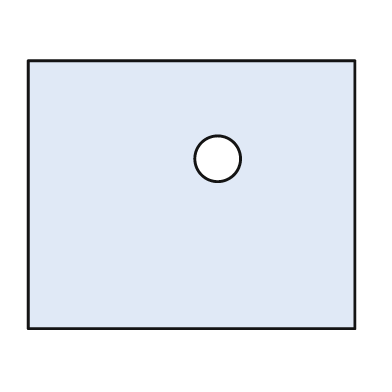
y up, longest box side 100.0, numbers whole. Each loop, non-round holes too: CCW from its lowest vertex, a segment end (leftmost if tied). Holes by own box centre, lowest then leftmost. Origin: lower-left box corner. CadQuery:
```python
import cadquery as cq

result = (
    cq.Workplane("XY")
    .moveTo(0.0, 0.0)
    .lineTo(100.0, 0.0)
    .lineTo(100.0, 82.0)
    .lineTo(0.0, 82.0)
    .close()
    .moveTo(58.0, 52.0)
    .circle(7.0)
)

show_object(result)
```